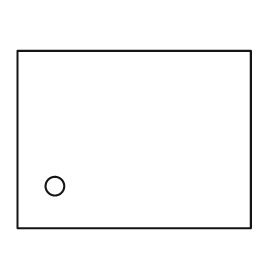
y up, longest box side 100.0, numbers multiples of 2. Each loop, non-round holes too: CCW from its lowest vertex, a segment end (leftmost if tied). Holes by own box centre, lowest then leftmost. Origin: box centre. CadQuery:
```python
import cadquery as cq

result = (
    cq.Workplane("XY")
    .moveTo(-50.0, -38.0)
    .lineTo(50.0, -38.0)
    .lineTo(50.0, 38.0)
    .lineTo(-50.0, 38.0)
    .close()
    .moveTo(-34.0, -20.0)
    .circle(4.0)
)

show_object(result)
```